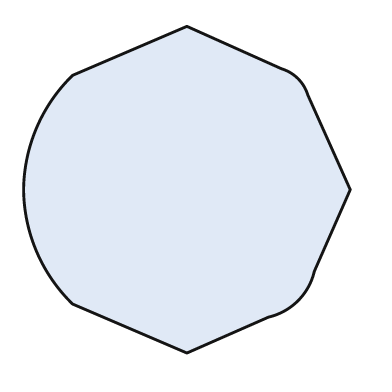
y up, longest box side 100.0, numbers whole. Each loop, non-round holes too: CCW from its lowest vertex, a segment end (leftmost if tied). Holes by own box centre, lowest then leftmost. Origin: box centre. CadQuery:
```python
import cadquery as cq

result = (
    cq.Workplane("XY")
    .moveTo(0.0, -50.0)
    .lineTo(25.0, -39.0)
    .threePointArc((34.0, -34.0), (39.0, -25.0))
    .lineTo(50.0, 0.0)
    .lineTo(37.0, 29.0)
    .threePointArc((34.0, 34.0), (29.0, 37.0))
    .lineTo(0.0, 50.0)
    .lineTo(-35.0, 35.0)
    .threePointArc((-46.0, 19.0), (-50.0, 0.0))
    .threePointArc((-46.0, -19.0), (-35.0, -35.0))
    .close()
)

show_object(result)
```